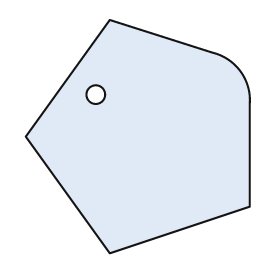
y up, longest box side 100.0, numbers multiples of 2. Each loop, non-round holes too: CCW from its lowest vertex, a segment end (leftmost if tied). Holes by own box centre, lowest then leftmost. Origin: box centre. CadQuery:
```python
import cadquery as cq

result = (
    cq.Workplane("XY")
    .moveTo(-12.0, -50.0)
    .lineTo(48.0, -30.0)
    .lineTo(48.0, 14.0)
    .threePointArc((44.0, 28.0), (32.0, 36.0))
    .lineTo(-12.0, 50.0)
    .lineTo(-48.0, 0.0)
    .close()
    .moveTo(-18.0, 18.0)
    .circle(4.0)
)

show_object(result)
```